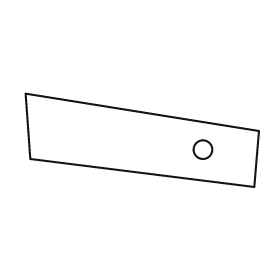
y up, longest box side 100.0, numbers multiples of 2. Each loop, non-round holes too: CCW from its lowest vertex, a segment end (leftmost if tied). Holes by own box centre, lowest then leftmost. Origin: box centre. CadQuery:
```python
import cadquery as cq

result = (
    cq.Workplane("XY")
    .moveTo(48.0, -20.0)
    .lineTo(50.0, 4.0)
    .lineTo(-50.0, 20.0)
    .lineTo(-48.0, -8.0)
    .close()
    .moveTo(26.0, -4.0)
    .circle(4.0)
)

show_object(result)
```